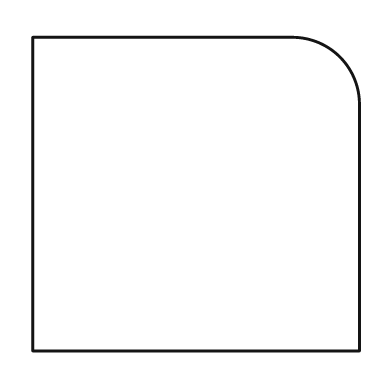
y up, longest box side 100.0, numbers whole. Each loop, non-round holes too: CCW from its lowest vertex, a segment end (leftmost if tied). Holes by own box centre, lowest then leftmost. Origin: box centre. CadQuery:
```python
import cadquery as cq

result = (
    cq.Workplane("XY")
    .moveTo(-50.0, -48.0)
    .lineTo(50.0, -48.0)
    .lineTo(50.0, 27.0)
    .threePointArc((44.0, 42.0), (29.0, 48.0))
    .lineTo(-50.0, 48.0)
    .close()
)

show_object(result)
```